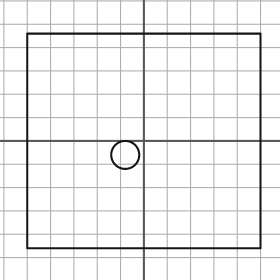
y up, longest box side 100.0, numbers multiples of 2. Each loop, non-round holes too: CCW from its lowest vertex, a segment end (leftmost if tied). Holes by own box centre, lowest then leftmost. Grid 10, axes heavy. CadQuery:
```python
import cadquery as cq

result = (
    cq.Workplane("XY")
    .moveTo(-50.0, -46.0)
    .lineTo(50.0, -46.0)
    .lineTo(50.0, 46.0)
    .lineTo(-50.0, 46.0)
    .close()
    .moveTo(-8.0, -6.0)
    .circle(6.0)
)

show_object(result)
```